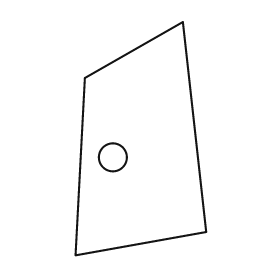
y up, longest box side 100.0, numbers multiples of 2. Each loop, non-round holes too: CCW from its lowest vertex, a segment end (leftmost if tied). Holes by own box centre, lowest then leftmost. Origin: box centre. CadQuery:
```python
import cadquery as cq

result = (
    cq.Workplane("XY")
    .moveTo(-28.0, -50.0)
    .lineTo(28.0, -40.0)
    .lineTo(18.0, 50.0)
    .lineTo(-24.0, 26.0)
    .close()
    .moveTo(-12.0, -8.0)
    .circle(6.0)
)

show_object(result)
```